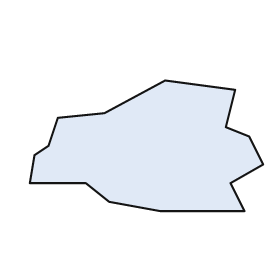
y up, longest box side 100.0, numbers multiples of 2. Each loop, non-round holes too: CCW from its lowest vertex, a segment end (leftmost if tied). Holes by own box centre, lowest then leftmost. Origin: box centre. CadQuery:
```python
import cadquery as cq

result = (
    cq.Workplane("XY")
    .moveTo(6.0, -28.0)
    .lineTo(42.0, -28.0)
    .lineTo(36.0, -16.0)
    .lineTo(50.0, -8.0)
    .lineTo(44.0, 4.0)
    .lineTo(34.0, 8.0)
    .lineTo(38.0, 24.0)
    .lineTo(8.0, 28.0)
    .lineTo(-18.0, 14.0)
    .lineTo(-38.0, 12.0)
    .lineTo(-42.0, 0.0)
    .lineTo(-48.0, -4.0)
    .lineTo(-50.0, -16.0)
    .lineTo(-26.0, -16.0)
    .lineTo(-16.0, -24.0)
    .close()
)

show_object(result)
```